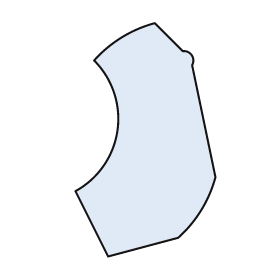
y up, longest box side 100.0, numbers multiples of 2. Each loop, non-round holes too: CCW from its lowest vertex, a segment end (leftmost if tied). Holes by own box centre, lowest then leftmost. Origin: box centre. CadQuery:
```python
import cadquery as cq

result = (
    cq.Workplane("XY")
    .moveTo(-16.0, -50.0)
    .lineTo(14.0, -42.0)
    .threePointArc((24.0, -30.0), (30.0, -16.0))
    .lineTo(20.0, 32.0)
    .threePointArc((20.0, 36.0), (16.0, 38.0))
    .lineTo(4.0, 50.0)
    .threePointArc((-10.0, 44.0), (-22.0, 34.0))
    .threePointArc((-12.0, 4.0), (-30.0, -22.0))
    .close()
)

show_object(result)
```